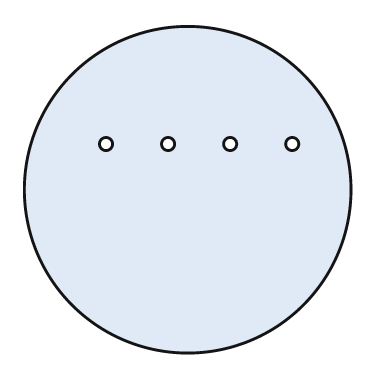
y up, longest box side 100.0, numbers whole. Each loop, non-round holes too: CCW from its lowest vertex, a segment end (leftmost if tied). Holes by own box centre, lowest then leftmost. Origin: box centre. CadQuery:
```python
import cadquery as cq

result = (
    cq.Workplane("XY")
    .moveTo(0.0, 0.0)
    .circle(50.0)
    .moveTo(-25.0, 14.0)
    .circle(2.0)
    .moveTo(-6.0, 14.0)
    .circle(2.0)
    .moveTo(13.0, 14.0)
    .circle(2.0)
    .moveTo(32.0, 14.0)
    .circle(2.0)
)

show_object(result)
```